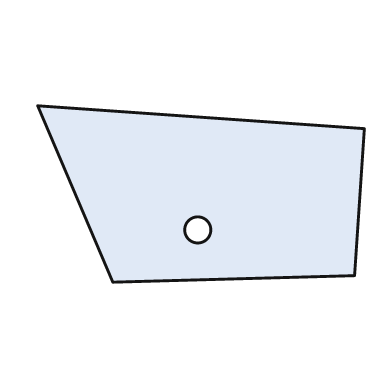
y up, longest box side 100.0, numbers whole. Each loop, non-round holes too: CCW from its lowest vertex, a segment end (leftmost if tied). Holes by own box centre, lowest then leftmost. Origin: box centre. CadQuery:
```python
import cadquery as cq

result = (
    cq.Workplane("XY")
    .moveTo(-27.0, -27.0)
    .lineTo(47.0, -25.0)
    .lineTo(50.0, 20.0)
    .lineTo(-50.0, 27.0)
    .close()
    .moveTo(-1.0, -11.0)
    .circle(4.0)
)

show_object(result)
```